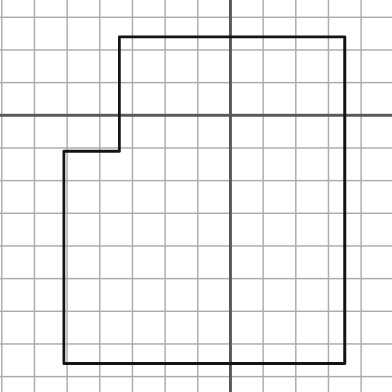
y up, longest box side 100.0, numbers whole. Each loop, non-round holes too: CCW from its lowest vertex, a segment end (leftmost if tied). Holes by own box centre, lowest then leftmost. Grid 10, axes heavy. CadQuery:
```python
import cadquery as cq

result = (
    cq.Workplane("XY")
    .moveTo(-51.0, -76.0)
    .lineTo(35.0, -76.0)
    .lineTo(35.0, 24.0)
    .lineTo(-34.0, 24.0)
    .lineTo(-34.0, -11.0)
    .lineTo(-51.0, -11.0)
    .close()
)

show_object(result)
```